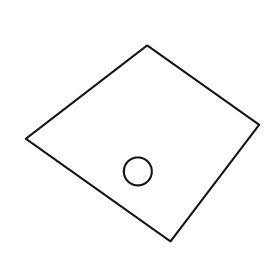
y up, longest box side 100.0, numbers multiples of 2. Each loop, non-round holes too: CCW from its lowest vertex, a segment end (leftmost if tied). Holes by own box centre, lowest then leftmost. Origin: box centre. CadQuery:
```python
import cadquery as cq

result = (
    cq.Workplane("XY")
    .moveTo(12.0, -42.0)
    .lineTo(50.0, 8.0)
    .lineTo(2.0, 42.0)
    .lineTo(-50.0, 2.0)
    .close()
    .moveTo(-2.0, -12.0)
    .circle(6.0)
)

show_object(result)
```